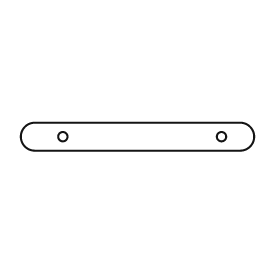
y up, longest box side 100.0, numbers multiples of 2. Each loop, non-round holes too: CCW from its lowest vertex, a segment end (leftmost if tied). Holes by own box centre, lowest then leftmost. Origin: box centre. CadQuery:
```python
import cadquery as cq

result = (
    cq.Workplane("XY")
    .moveTo(-44.0, -6.0)
    .lineTo(44.0, -6.0)
    .threePointArc((50.0, 0.0), (44.0, 6.0))
    .lineTo(-44.0, 6.0)
    .threePointArc((-50.0, 0.0), (-44.0, -6.0))
    .close()
    .moveTo(-32.0, 0.0)
    .circle(2.0)
    .moveTo(36.0, 0.0)
    .circle(2.0)
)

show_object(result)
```